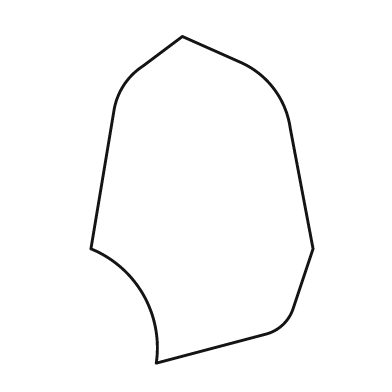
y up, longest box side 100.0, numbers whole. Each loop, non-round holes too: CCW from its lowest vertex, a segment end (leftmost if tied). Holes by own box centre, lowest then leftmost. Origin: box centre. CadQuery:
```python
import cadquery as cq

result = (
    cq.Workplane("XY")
    .moveTo(-14.0, -50.0)
    .lineTo(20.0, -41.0)
    .threePointArc((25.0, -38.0), (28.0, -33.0))
    .lineTo(34.0, -15.0)
    .lineTo(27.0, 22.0)
    .threePointArc((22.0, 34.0), (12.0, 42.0))
    .lineTo(-6.0, 50.0)
    .lineTo(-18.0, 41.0)
    .threePointArc((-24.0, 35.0), (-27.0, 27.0))
    .lineTo(-34.0, -15.0)
    .threePointArc((-18.0, -29.0), (-14.0, -50.0))
    .close()
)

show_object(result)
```